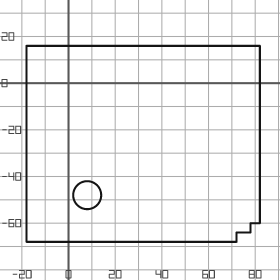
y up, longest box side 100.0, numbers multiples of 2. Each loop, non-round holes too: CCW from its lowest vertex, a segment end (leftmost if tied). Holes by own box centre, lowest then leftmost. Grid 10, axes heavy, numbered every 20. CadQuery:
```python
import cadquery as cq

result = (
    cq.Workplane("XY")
    .moveTo(-18.0, -68.0)
    .lineTo(72.0, -68.0)
    .lineTo(72.0, -64.0)
    .lineTo(78.0, -64.0)
    .lineTo(78.0, -60.0)
    .lineTo(82.0, -60.0)
    .lineTo(82.0, 16.0)
    .lineTo(-18.0, 16.0)
    .close()
    .moveTo(8.0, -48.0)
    .circle(6.0)
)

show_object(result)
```